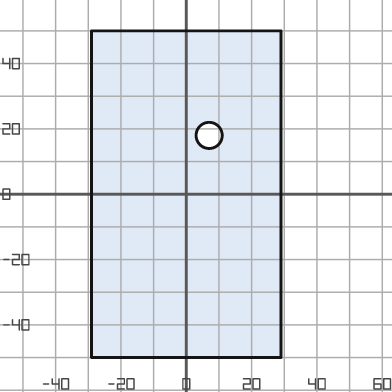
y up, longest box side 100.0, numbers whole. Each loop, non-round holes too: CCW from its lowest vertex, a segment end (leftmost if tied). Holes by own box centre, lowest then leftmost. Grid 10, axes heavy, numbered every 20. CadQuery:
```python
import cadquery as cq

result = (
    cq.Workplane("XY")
    .moveTo(-29.0, -50.0)
    .lineTo(29.0, -50.0)
    .lineTo(29.0, 50.0)
    .lineTo(-29.0, 50.0)
    .close()
    .moveTo(7.0, 18.0)
    .circle(4.0)
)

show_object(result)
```